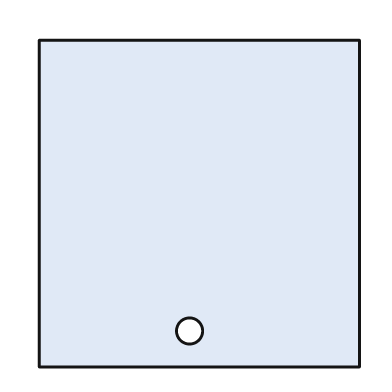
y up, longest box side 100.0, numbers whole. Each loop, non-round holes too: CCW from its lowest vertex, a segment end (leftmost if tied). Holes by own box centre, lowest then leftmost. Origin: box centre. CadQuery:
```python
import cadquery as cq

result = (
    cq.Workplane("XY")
    .moveTo(-49.0, -50.0)
    .lineTo(49.0, -50.0)
    .lineTo(49.0, 50.0)
    .lineTo(-49.0, 50.0)
    .close()
    .moveTo(-3.0, -39.0)
    .circle(4.0)
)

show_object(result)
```